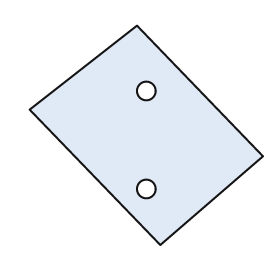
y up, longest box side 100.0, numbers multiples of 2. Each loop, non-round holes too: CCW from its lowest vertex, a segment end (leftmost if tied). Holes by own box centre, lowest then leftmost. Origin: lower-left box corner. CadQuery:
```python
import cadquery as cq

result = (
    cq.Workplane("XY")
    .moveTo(56.0, 0.0)
    .lineTo(100.0, 38.0)
    .lineTo(46.0, 94.0)
    .lineTo(0.0, 58.0)
    .close()
    .moveTo(50.0, 24.0)
    .circle(4.0)
    .moveTo(50.0, 66.0)
    .circle(4.0)
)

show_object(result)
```